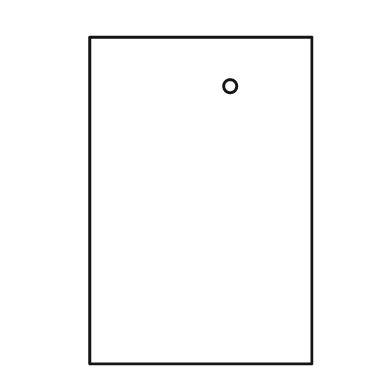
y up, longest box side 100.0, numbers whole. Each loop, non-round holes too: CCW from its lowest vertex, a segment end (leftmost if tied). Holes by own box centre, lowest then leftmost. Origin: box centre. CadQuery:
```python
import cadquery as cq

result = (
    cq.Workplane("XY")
    .moveTo(-34.0, -50.0)
    .lineTo(34.0, -50.0)
    .lineTo(34.0, 50.0)
    .lineTo(-34.0, 50.0)
    .close()
    .moveTo(9.0, 35.0)
    .circle(2.0)
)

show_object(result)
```